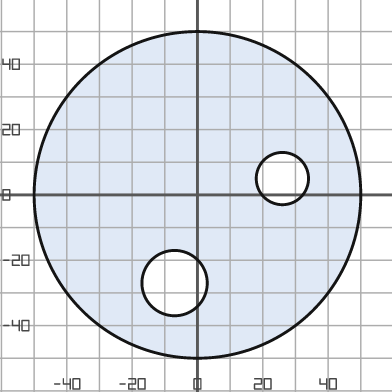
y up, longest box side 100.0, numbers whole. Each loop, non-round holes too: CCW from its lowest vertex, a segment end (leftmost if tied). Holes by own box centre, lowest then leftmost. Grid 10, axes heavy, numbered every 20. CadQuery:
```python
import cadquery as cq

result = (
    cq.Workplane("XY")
    .moveTo(0.0, 0.0)
    .circle(50.0)
    .moveTo(-7.0, -27.0)
    .circle(10.0)
    .moveTo(26.0, 5.0)
    .circle(8.0)
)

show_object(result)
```